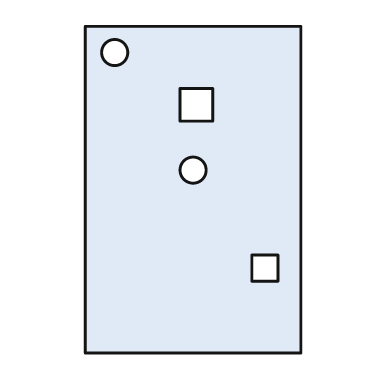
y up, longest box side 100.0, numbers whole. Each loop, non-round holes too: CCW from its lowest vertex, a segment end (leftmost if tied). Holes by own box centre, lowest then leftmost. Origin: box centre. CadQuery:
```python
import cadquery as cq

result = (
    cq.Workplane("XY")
    .moveTo(-33.0, -50.0)
    .lineTo(33.0, -50.0)
    .lineTo(33.0, 50.0)
    .lineTo(-33.0, 50.0)
    .close()
    .moveTo(18.0, -28.0)
    .lineTo(26.0, -28.0)
    .lineTo(26.0, -20.0)
    .lineTo(18.0, -20.0)
    .close()
    .moveTo(0.0, 6.0)
    .circle(4.0)
    .moveTo(-4.0, 21.0)
    .lineTo(6.0, 21.0)
    .lineTo(6.0, 31.0)
    .lineTo(-4.0, 31.0)
    .close()
    .moveTo(-24.0, 42.0)
    .circle(4.0)
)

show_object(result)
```